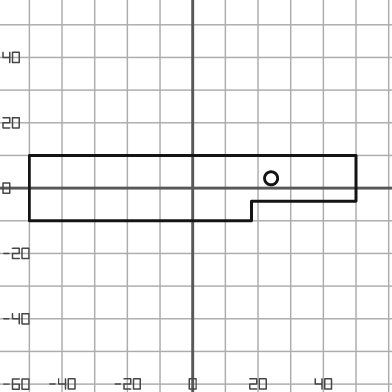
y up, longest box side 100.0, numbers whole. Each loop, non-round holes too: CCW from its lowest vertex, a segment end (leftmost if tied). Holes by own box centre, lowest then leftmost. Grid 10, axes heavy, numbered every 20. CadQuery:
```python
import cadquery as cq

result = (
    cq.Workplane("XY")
    .moveTo(-50.0, -10.0)
    .lineTo(18.0, -10.0)
    .lineTo(18.0, -4.0)
    .lineTo(50.0, -4.0)
    .lineTo(50.0, 10.0)
    .lineTo(-50.0, 10.0)
    .close()
    .moveTo(24.0, 3.0)
    .circle(2.0)
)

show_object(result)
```